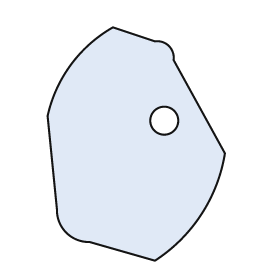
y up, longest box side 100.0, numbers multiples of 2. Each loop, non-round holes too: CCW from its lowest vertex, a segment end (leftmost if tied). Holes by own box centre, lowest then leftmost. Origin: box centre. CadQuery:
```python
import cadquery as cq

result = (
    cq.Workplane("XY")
    .moveTo(8.0, -50.0)
    .threePointArc((28.0, -30.0), (38.0, -4.0))
    .lineTo(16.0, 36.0)
    .threePointArc((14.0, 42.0), (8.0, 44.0))
    .lineTo(-10.0, 50.0)
    .threePointArc((-28.0, 34.0), (-38.0, 12.0))
    .lineTo(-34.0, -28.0)
    .threePointArc((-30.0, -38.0), (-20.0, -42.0))
    .close()
    .moveTo(12.0, 10.0)
    .circle(6.0)
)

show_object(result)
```